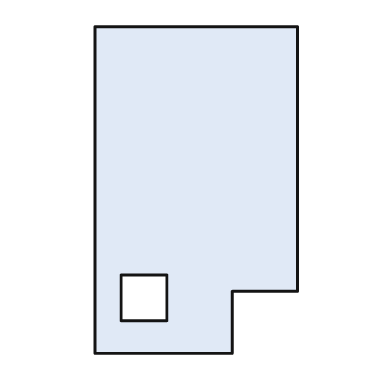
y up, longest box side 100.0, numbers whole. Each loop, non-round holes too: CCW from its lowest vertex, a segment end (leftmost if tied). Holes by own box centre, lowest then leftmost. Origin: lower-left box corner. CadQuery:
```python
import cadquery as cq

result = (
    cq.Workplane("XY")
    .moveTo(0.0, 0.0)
    .lineTo(42.0, 0.0)
    .lineTo(42.0, 19.0)
    .lineTo(62.0, 19.0)
    .lineTo(62.0, 100.0)
    .lineTo(0.0, 100.0)
    .close()
    .moveTo(8.0, 10.0)
    .lineTo(22.0, 10.0)
    .lineTo(22.0, 24.0)
    .lineTo(8.0, 24.0)
    .close()
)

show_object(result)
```